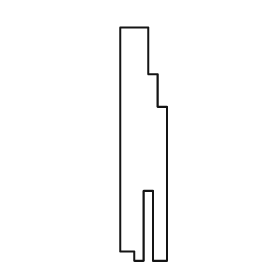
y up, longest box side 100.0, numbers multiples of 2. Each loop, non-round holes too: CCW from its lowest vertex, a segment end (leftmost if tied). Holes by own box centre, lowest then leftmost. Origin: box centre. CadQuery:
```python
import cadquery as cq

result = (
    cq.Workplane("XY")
    .moveTo(-4.0, -50.0)
    .lineTo(0.0, -50.0)
    .lineTo(0.0, -20.0)
    .lineTo(4.0, -20.0)
    .lineTo(4.0, -50.0)
    .lineTo(10.0, -50.0)
    .lineTo(10.0, 16.0)
    .lineTo(6.0, 16.0)
    .lineTo(6.0, 30.0)
    .lineTo(2.0, 30.0)
    .lineTo(2.0, 50.0)
    .lineTo(-10.0, 50.0)
    .lineTo(-10.0, -46.0)
    .lineTo(-4.0, -46.0)
    .close()
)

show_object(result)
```